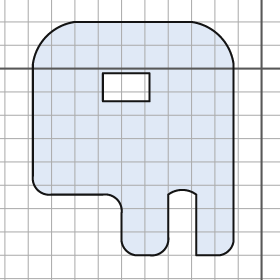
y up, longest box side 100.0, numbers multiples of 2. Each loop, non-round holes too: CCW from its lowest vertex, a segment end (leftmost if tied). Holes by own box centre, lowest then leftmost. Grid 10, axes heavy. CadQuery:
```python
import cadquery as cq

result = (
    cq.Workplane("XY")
    .moveTo(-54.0, -80.0)
    .lineTo(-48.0, -80.0)
    .threePointArc((-42.0, -78.0), (-40.0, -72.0))
    .lineTo(-40.0, -54.0)
    .threePointArc((-34.0, -52.0), (-28.0, -54.0))
    .lineTo(-28.0, -80.0)
    .lineTo(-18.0, -80.0)
    .threePointArc((-14.0, -78.0), (-12.0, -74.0))
    .lineTo(-12.0, 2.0)
    .threePointArc((-18.0, 14.0), (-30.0, 20.0))
    .lineTo(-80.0, 20.0)
    .threePointArc((-92.0, 14.0), (-98.0, 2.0))
    .lineTo(-98.0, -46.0)
    .threePointArc((-96.0, -52.0), (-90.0, -54.0))
    .lineTo(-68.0, -54.0)
    .threePointArc((-62.0, -56.0), (-60.0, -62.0))
    .lineTo(-60.0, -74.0)
    .threePointArc((-58.0, -78.0), (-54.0, -80.0))
    .close()
    .moveTo(-68.0, -14.0)
    .lineTo(-48.0, -14.0)
    .lineTo(-48.0, -2.0)
    .lineTo(-68.0, -2.0)
    .close()
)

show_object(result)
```